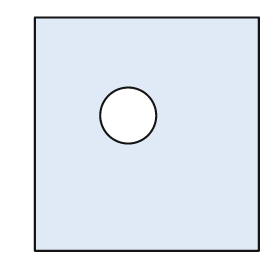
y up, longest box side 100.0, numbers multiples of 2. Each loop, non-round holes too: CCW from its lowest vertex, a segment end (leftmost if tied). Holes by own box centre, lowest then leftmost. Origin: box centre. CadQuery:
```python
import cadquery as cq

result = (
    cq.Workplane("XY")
    .moveTo(-48.0, -50.0)
    .lineTo(48.0, -50.0)
    .lineTo(48.0, 50.0)
    .lineTo(-48.0, 50.0)
    .close()
    .moveTo(-8.0, 8.0)
    .circle(12.0)
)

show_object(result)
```